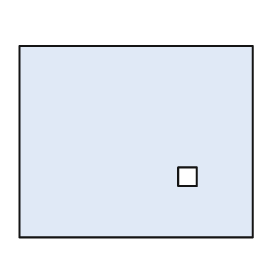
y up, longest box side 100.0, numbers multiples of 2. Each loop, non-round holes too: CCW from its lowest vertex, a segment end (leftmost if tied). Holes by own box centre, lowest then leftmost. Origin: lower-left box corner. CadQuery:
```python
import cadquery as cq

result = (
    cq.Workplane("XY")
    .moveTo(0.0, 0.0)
    .lineTo(100.0, 0.0)
    .lineTo(100.0, 82.0)
    .lineTo(0.0, 82.0)
    .close()
    .moveTo(68.0, 22.0)
    .lineTo(76.0, 22.0)
    .lineTo(76.0, 30.0)
    .lineTo(68.0, 30.0)
    .close()
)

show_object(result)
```